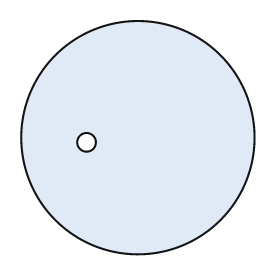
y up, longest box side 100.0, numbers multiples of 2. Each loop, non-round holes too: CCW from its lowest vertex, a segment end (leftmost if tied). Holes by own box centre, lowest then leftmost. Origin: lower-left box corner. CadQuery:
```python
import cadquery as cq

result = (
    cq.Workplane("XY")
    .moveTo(50.0, 50.0)
    .circle(50.0)
    .moveTo(28.0, 48.0)
    .circle(4.0)
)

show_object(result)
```